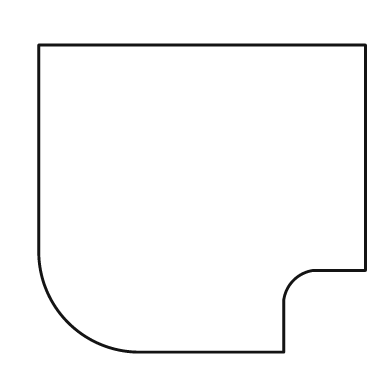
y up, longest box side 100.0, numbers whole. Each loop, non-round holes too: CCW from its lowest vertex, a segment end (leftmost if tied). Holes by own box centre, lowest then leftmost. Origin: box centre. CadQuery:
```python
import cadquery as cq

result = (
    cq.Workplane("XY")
    .moveTo(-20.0, -47.0)
    .lineTo(25.0, -47.0)
    .lineTo(25.0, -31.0)
    .threePointArc((28.0, -25.0), (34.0, -22.0))
    .lineTo(50.0, -22.0)
    .lineTo(50.0, 47.0)
    .lineTo(-50.0, 47.0)
    .lineTo(-50.0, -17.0)
    .threePointArc((-41.0, -38.0), (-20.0, -47.0))
    .close()
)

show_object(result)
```